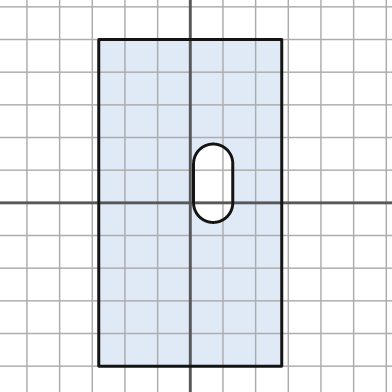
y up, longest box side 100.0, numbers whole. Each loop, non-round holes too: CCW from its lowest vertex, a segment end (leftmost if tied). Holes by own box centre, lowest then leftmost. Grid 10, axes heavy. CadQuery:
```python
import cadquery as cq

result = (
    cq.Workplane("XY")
    .moveTo(-28.0, -50.0)
    .lineTo(28.0, -50.0)
    .lineTo(28.0, 50.0)
    .lineTo(-28.0, 50.0)
    .close()
    .moveTo(1.0, 0.0)
    .threePointArc((7.0, -6.0), (13.0, 0.0))
    .lineTo(13.0, 12.0)
    .threePointArc((7.0, 18.0), (1.0, 12.0))
    .close()
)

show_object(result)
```